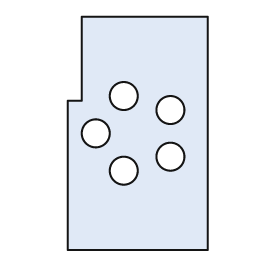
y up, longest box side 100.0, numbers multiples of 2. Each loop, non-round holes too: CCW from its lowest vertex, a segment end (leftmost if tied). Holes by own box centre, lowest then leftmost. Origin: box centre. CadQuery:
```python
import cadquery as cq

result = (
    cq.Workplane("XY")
    .moveTo(-30.0, -50.0)
    .lineTo(30.0, -50.0)
    .lineTo(30.0, 50.0)
    .lineTo(-24.0, 50.0)
    .lineTo(-24.0, 14.0)
    .lineTo(-30.0, 14.0)
    .close()
    .moveTo(-6.0, -16.0)
    .circle(6.0)
    .moveTo(14.0, -10.0)
    .circle(6.0)
    .moveTo(-18.0, 0.0)
    .circle(6.0)
    .moveTo(14.0, 10.0)
    .circle(6.0)
    .moveTo(-6.0, 16.0)
    .circle(6.0)
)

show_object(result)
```